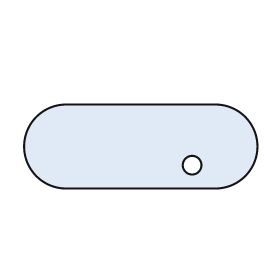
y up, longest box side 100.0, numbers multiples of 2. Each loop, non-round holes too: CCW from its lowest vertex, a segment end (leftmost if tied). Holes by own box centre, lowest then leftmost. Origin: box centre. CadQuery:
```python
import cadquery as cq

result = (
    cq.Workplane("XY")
    .moveTo(-32.0, -18.0)
    .lineTo(32.0, -18.0)
    .threePointArc((50.0, 0.0), (32.0, 18.0))
    .lineTo(-32.0, 18.0)
    .threePointArc((-50.0, 0.0), (-32.0, -18.0))
    .close()
    .moveTo(22.0, -8.0)
    .circle(4.0)
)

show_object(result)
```